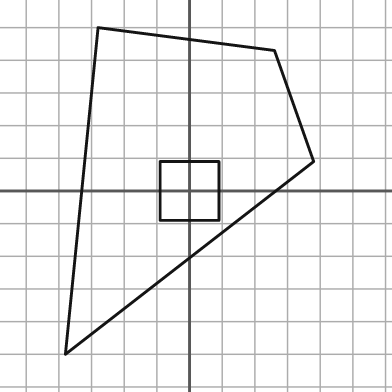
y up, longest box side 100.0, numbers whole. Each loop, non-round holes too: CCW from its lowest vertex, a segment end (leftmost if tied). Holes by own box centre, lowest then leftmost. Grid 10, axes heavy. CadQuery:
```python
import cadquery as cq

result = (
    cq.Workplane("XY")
    .moveTo(-38.0, -50.0)
    .lineTo(38.0, 9.0)
    .lineTo(26.0, 43.0)
    .lineTo(-28.0, 50.0)
    .close()
    .moveTo(-9.0, -9.0)
    .lineTo(9.0, -9.0)
    .lineTo(9.0, 9.0)
    .lineTo(-9.0, 9.0)
    .close()
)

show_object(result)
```